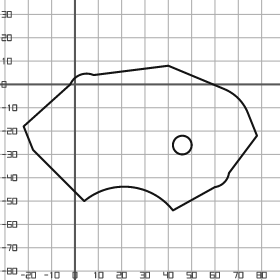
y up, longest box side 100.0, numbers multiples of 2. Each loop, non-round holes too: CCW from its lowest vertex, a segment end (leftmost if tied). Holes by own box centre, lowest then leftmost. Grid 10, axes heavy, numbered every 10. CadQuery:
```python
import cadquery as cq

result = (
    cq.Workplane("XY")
    .moveTo(42.0, -54.0)
    .lineTo(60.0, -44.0)
    .threePointArc((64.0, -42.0), (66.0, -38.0))
    .lineTo(78.0, -22.0)
    .lineTo(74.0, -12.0)
    .threePointArc((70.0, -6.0), (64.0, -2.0))
    .lineTo(40.0, 8.0)
    .lineTo(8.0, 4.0)
    .threePointArc((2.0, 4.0), (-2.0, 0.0))
    .lineTo(-22.0, -18.0)
    .lineTo(-18.0, -28.0)
    .lineTo(4.0, -50.0)
    .threePointArc((24.0, -44.0), (42.0, -54.0))
    .close()
    .moveTo(46.0, -26.0)
    .circle(4.0)
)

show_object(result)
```